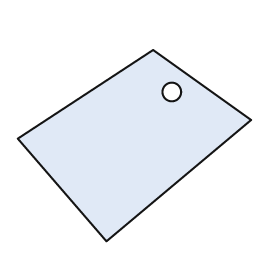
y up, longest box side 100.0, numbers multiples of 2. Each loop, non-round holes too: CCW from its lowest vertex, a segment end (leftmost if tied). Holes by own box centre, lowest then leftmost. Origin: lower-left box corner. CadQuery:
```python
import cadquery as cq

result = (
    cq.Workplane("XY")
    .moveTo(38.0, 0.0)
    .lineTo(100.0, 52.0)
    .lineTo(58.0, 82.0)
    .lineTo(0.0, 44.0)
    .close()
    .moveTo(66.0, 64.0)
    .circle(4.0)
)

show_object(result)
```